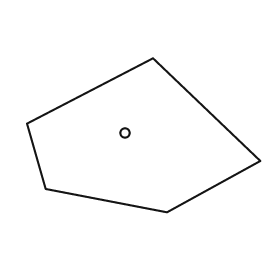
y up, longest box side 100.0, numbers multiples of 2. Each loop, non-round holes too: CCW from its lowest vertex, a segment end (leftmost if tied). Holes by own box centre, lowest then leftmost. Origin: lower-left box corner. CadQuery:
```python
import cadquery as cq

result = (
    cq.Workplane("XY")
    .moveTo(60.0, 0.0)
    .lineTo(100.0, 22.0)
    .lineTo(54.0, 66.0)
    .lineTo(0.0, 38.0)
    .lineTo(8.0, 10.0)
    .close()
    .moveTo(42.0, 34.0)
    .circle(2.0)
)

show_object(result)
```